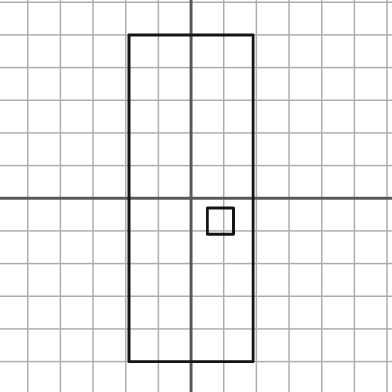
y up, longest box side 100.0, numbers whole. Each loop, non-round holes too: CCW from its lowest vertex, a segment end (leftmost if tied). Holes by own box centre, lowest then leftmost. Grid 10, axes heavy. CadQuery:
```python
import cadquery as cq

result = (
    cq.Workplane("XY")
    .moveTo(-19.0, -50.0)
    .lineTo(19.0, -50.0)
    .lineTo(19.0, 50.0)
    .lineTo(-19.0, 50.0)
    .close()
    .moveTo(5.0, -11.0)
    .lineTo(13.0, -11.0)
    .lineTo(13.0, -3.0)
    .lineTo(5.0, -3.0)
    .close()
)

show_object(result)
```